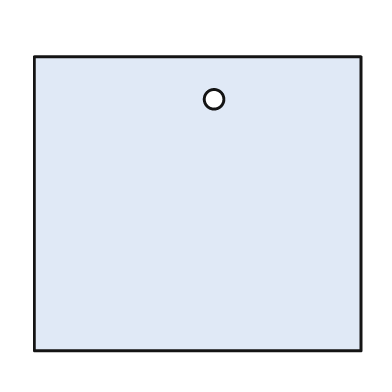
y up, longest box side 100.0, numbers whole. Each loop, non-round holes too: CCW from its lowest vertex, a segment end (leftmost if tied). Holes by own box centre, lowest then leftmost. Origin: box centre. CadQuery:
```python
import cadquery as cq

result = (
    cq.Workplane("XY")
    .moveTo(-50.0, -45.0)
    .lineTo(50.0, -45.0)
    .lineTo(50.0, 45.0)
    .lineTo(-50.0, 45.0)
    .close()
    .moveTo(5.0, 32.0)
    .circle(3.0)
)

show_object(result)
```